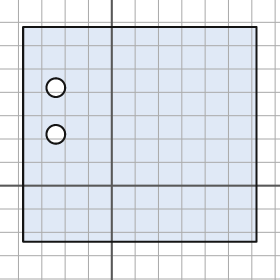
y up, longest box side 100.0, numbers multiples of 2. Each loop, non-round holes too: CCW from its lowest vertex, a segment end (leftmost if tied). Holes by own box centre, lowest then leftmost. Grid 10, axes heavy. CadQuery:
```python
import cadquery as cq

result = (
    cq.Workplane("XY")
    .moveTo(-38.0, -24.0)
    .lineTo(62.0, -24.0)
    .lineTo(62.0, 68.0)
    .lineTo(-38.0, 68.0)
    .close()
    .moveTo(-24.0, 22.0)
    .circle(4.0)
    .moveTo(-24.0, 42.0)
    .circle(4.0)
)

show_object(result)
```